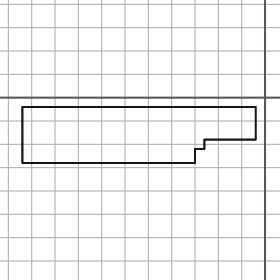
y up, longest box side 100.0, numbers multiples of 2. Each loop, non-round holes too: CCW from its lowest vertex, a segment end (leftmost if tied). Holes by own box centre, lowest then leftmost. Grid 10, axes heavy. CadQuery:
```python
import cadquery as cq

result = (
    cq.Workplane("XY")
    .moveTo(-104.0, -28.0)
    .lineTo(-30.0, -28.0)
    .lineTo(-30.0, -22.0)
    .lineTo(-26.0, -22.0)
    .lineTo(-26.0, -18.0)
    .lineTo(-4.0, -18.0)
    .lineTo(-4.0, -4.0)
    .lineTo(-104.0, -4.0)
    .close()
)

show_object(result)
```